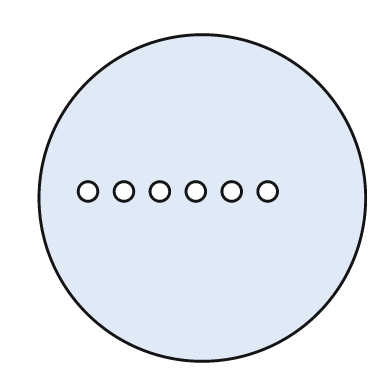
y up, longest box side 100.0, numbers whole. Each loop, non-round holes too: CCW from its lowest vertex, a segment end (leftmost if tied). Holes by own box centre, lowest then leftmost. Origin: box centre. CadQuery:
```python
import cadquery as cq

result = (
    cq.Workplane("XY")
    .moveTo(0.0, 0.0)
    .circle(50.0)
    .moveTo(-35.0, 2.0)
    .circle(3.0)
    .moveTo(-24.0, 2.0)
    .circle(3.0)
    .moveTo(-13.0, 2.0)
    .circle(3.0)
    .moveTo(-2.0, 2.0)
    .circle(3.0)
    .moveTo(9.0, 2.0)
    .circle(3.0)
    .moveTo(20.0, 2.0)
    .circle(3.0)
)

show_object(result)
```